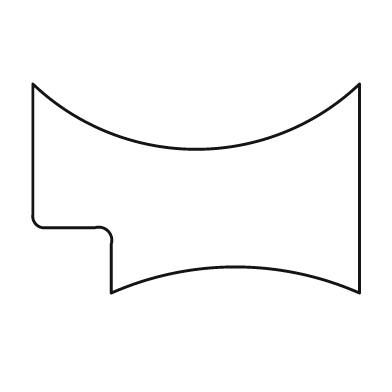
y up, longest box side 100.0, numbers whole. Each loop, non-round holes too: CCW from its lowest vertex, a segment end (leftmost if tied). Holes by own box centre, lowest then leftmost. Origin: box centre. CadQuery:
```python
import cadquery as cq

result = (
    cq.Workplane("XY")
    .moveTo(-26.0, -32.0)
    .threePointArc((12.0, -24.0), (50.0, -32.0))
    .lineTo(50.0, 32.0)
    .threePointArc((0.0, 12.0), (-50.0, 32.0))
    .lineTo(-50.0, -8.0)
    .threePointArc((-49.0, -11.0), (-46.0, -12.0))
    .lineTo(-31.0, -12.0)
    .threePointArc((-27.0, -13.0), (-26.0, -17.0))
    .close()
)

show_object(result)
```